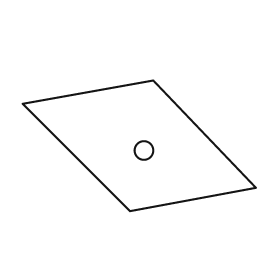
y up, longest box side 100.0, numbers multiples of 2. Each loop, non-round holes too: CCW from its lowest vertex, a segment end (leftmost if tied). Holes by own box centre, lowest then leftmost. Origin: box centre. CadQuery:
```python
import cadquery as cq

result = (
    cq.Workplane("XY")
    .moveTo(-4.0, -28.0)
    .lineTo(50.0, -18.0)
    .lineTo(6.0, 28.0)
    .lineTo(-50.0, 18.0)
    .close()
    .moveTo(2.0, -2.0)
    .circle(4.0)
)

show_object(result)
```